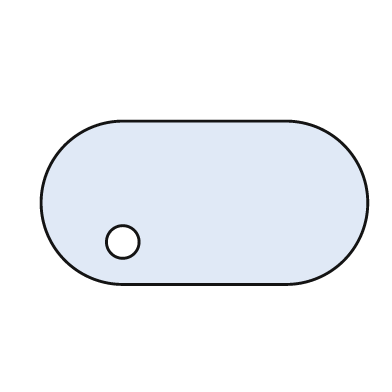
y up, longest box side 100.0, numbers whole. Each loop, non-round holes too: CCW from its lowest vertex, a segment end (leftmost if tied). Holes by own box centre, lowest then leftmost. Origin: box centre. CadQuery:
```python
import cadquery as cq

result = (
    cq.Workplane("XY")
    .moveTo(-25.0, -25.0)
    .lineTo(25.0, -25.0)
    .threePointArc((50.0, 0.0), (25.0, 25.0))
    .lineTo(-25.0, 25.0)
    .threePointArc((-50.0, 0.0), (-25.0, -25.0))
    .close()
    .moveTo(-25.0, -12.0)
    .circle(5.0)
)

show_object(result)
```